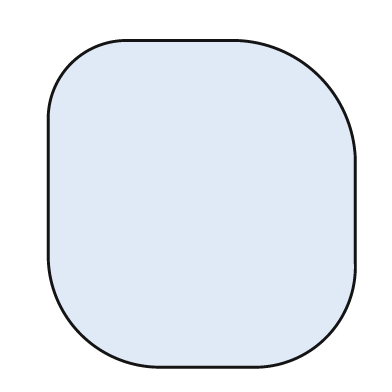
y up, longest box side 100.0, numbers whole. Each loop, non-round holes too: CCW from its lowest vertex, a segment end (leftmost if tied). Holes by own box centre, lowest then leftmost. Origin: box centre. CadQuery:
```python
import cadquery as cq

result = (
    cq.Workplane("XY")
    .moveTo(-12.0, -50.0)
    .lineTo(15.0, -50.0)
    .threePointArc((38.0, -41.0), (47.0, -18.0))
    .lineTo(47.0, 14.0)
    .threePointArc((36.0, 39.0), (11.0, 50.0))
    .lineTo(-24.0, 50.0)
    .threePointArc((-40.0, 43.0), (-47.0, 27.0))
    .lineTo(-47.0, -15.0)
    .threePointArc((-37.0, -40.0), (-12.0, -50.0))
    .close()
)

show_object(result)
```